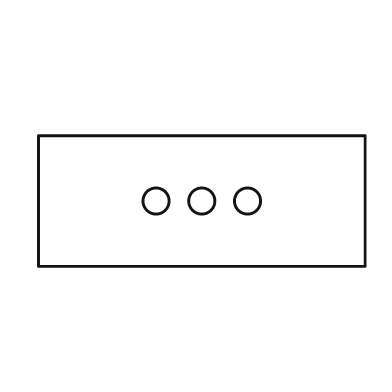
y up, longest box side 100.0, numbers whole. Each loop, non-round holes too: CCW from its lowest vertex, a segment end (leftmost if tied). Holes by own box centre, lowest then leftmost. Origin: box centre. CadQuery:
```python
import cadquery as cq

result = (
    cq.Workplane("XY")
    .moveTo(-50.0, -20.0)
    .lineTo(50.0, -20.0)
    .lineTo(50.0, 20.0)
    .lineTo(-50.0, 20.0)
    .close()
    .moveTo(-14.0, 0.0)
    .circle(4.0)
    .moveTo(0.0, 0.0)
    .circle(4.0)
    .moveTo(14.0, 0.0)
    .circle(4.0)
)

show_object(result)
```